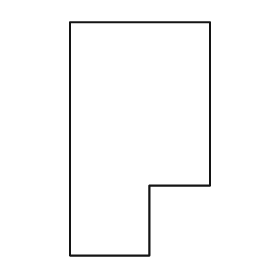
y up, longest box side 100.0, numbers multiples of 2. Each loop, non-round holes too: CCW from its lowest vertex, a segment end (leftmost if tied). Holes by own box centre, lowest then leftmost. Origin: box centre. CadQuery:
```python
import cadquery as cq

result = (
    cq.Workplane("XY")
    .moveTo(-30.0, -50.0)
    .lineTo(4.0, -50.0)
    .lineTo(4.0, -20.0)
    .lineTo(30.0, -20.0)
    .lineTo(30.0, 50.0)
    .lineTo(-30.0, 50.0)
    .close()
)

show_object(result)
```